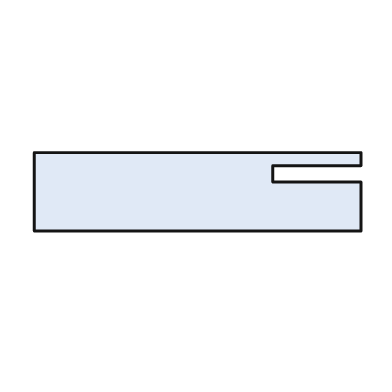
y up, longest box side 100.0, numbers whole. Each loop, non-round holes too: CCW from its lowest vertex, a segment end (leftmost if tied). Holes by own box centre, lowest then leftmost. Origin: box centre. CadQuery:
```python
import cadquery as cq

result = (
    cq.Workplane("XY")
    .moveTo(-50.0, -12.0)
    .lineTo(50.0, -12.0)
    .lineTo(50.0, 3.0)
    .lineTo(23.0, 3.0)
    .lineTo(23.0, 8.0)
    .lineTo(50.0, 8.0)
    .lineTo(50.0, 12.0)
    .lineTo(-50.0, 12.0)
    .close()
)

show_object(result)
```